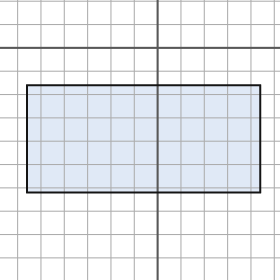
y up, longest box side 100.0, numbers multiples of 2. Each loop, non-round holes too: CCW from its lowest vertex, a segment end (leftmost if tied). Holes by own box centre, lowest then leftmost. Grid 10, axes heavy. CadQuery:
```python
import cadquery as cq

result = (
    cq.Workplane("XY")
    .moveTo(-56.0, -62.0)
    .lineTo(44.0, -62.0)
    .lineTo(44.0, -16.0)
    .lineTo(-56.0, -16.0)
    .close()
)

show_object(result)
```